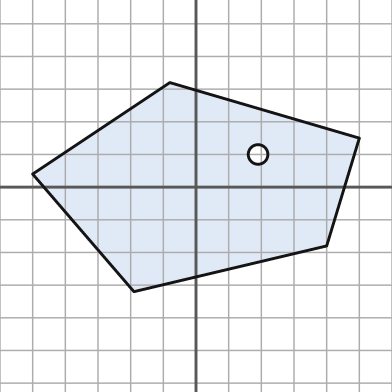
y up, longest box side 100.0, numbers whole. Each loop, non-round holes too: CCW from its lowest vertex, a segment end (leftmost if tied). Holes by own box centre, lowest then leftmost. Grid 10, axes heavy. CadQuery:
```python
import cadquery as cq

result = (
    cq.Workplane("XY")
    .moveTo(-19.0, -32.0)
    .lineTo(40.0, -18.0)
    .lineTo(50.0, 15.0)
    .lineTo(-8.0, 32.0)
    .lineTo(-50.0, 4.0)
    .close()
    .moveTo(19.0, 10.0)
    .circle(3.0)
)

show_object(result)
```